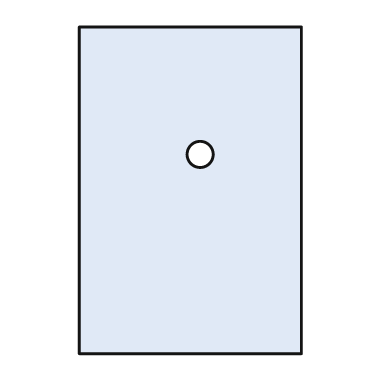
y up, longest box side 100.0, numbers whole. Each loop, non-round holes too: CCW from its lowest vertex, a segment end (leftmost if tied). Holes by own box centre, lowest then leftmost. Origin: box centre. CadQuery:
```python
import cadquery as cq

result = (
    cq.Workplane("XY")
    .moveTo(-34.0, -50.0)
    .lineTo(34.0, -50.0)
    .lineTo(34.0, 50.0)
    .lineTo(-34.0, 50.0)
    .close()
    .moveTo(3.0, 11.0)
    .circle(4.0)
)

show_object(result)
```